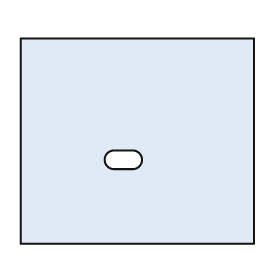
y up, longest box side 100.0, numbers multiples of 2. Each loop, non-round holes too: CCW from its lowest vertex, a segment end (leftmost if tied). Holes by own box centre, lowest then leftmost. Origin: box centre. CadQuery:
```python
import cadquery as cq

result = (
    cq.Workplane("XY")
    .moveTo(-50.0, -44.0)
    .lineTo(50.0, -44.0)
    .lineTo(50.0, 44.0)
    .lineTo(-50.0, 44.0)
    .close()
    .moveTo(-10.0, -12.0)
    .lineTo(-2.0, -12.0)
    .threePointArc((2.0, -8.0), (-2.0, -4.0))
    .lineTo(-10.0, -4.0)
    .threePointArc((-14.0, -8.0), (-10.0, -12.0))
    .close()
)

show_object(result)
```